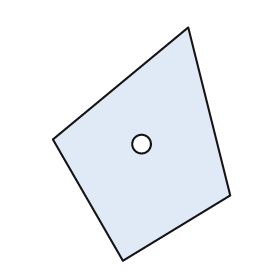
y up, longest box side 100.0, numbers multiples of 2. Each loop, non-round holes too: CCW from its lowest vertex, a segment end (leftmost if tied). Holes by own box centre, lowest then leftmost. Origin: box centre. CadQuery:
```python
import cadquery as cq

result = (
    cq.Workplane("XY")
    .moveTo(-8.0, -50.0)
    .lineTo(38.0, -22.0)
    .lineTo(20.0, 50.0)
    .lineTo(-38.0, 2.0)
    .close()
    .moveTo(0.0, 0.0)
    .circle(4.0)
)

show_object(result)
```